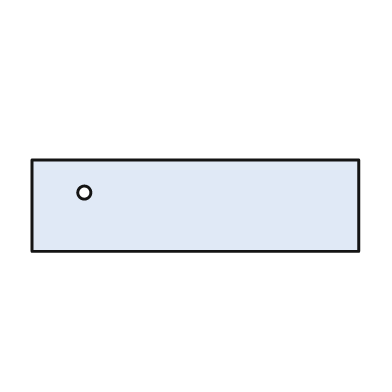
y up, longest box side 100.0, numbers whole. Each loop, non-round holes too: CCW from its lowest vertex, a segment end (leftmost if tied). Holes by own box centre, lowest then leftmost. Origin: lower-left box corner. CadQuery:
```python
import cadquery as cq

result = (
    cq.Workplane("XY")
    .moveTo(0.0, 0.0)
    .lineTo(100.0, 0.0)
    .lineTo(100.0, 28.0)
    .lineTo(0.0, 28.0)
    .close()
    .moveTo(16.0, 18.0)
    .circle(2.0)
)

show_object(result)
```